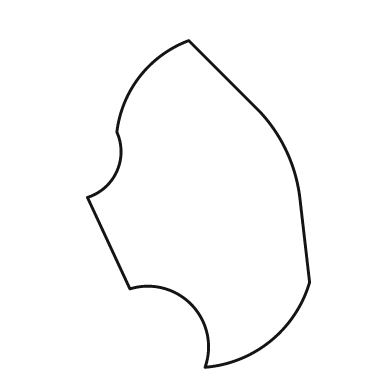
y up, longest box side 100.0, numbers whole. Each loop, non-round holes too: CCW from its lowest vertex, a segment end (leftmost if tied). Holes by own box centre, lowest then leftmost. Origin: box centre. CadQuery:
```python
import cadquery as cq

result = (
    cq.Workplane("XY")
    .moveTo(2.0, -50.0)
    .threePointArc((22.0, -42.0), (34.0, -24.0))
    .lineTo(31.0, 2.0)
    .threePointArc((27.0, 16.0), (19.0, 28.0))
    .lineTo(-3.0, 50.0)
    .threePointArc((-18.0, 39.0), (-25.0, 22.0))
    .threePointArc((-25.0, 10.0), (-34.0, 2.0))
    .lineTo(-21.0, -26.0)
    .threePointArc((-2.0, -31.0), (2.0, -50.0))
    .close()
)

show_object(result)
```